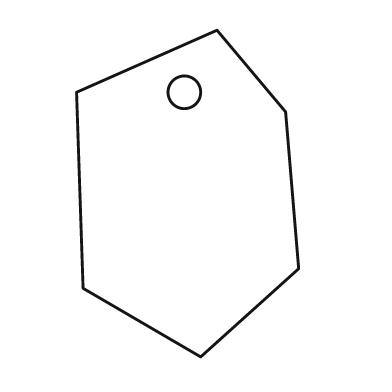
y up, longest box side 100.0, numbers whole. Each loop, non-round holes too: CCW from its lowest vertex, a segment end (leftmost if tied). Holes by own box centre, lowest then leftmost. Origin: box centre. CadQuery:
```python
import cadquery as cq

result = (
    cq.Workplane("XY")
    .moveTo(4.0, -50.0)
    .lineTo(34.0, -23.0)
    .lineTo(30.0, 25.0)
    .lineTo(9.0, 50.0)
    .lineTo(-34.0, 31.0)
    .lineTo(-32.0, -29.0)
    .close()
    .moveTo(-1.0, 31.0)
    .circle(5.0)
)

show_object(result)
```